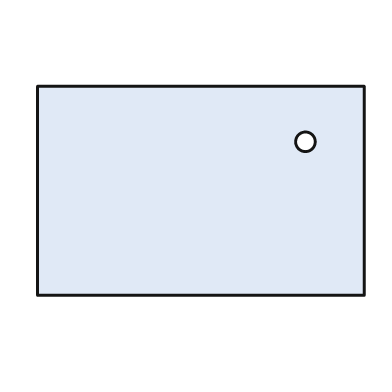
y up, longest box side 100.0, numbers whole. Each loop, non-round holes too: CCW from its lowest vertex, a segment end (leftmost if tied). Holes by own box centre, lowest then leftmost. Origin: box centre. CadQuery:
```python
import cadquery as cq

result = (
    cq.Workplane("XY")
    .moveTo(-50.0, -32.0)
    .lineTo(50.0, -32.0)
    .lineTo(50.0, 32.0)
    .lineTo(-50.0, 32.0)
    .close()
    .moveTo(32.0, 15.0)
    .circle(3.0)
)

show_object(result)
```